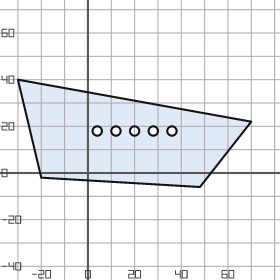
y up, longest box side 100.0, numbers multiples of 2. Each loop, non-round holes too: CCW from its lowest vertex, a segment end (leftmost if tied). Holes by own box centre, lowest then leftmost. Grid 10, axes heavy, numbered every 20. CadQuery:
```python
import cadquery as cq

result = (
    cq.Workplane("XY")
    .moveTo(48.0, -6.0)
    .lineTo(70.0, 22.0)
    .lineTo(-30.0, 40.0)
    .lineTo(-20.0, -2.0)
    .close()
    .moveTo(4.0, 18.0)
    .circle(2.0)
    .moveTo(12.0, 18.0)
    .circle(2.0)
    .moveTo(20.0, 18.0)
    .circle(2.0)
    .moveTo(28.0, 18.0)
    .circle(2.0)
    .moveTo(36.0, 18.0)
    .circle(2.0)
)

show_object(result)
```